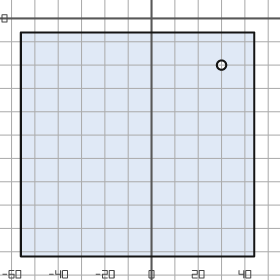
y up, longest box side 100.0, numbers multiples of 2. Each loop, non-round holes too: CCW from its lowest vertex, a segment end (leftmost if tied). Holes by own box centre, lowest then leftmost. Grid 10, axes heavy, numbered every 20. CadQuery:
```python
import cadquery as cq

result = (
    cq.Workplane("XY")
    .moveTo(-56.0, -102.0)
    .lineTo(44.0, -102.0)
    .lineTo(44.0, -6.0)
    .lineTo(-56.0, -6.0)
    .close()
    .moveTo(30.0, -20.0)
    .circle(2.0)
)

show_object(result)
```